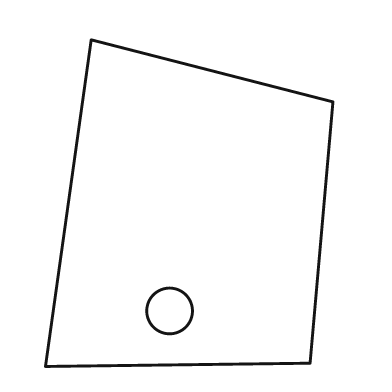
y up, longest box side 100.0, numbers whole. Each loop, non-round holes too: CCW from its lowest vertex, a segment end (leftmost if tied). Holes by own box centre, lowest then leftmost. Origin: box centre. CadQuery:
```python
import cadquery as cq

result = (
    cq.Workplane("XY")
    .moveTo(-44.0, -50.0)
    .lineTo(37.0, -49.0)
    .lineTo(44.0, 31.0)
    .lineTo(-30.0, 50.0)
    .close()
    .moveTo(-6.0, -33.0)
    .circle(7.0)
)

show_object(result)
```